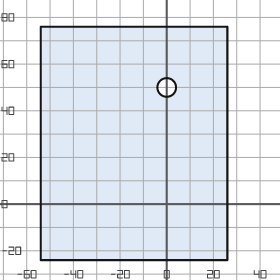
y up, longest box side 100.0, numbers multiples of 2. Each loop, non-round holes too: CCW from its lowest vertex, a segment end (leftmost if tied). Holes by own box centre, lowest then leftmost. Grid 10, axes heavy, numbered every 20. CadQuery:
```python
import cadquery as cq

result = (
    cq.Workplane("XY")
    .moveTo(-54.0, -24.0)
    .lineTo(26.0, -24.0)
    .lineTo(26.0, 76.0)
    .lineTo(-54.0, 76.0)
    .close()
    .moveTo(0.0, 50.0)
    .circle(4.0)
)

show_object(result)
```